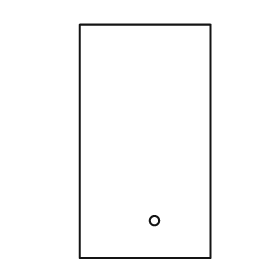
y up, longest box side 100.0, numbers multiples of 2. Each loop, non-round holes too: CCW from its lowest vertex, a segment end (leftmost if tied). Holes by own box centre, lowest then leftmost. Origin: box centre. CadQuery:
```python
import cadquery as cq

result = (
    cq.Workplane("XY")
    .moveTo(-28.0, -50.0)
    .lineTo(28.0, -50.0)
    .lineTo(28.0, 50.0)
    .lineTo(-28.0, 50.0)
    .close()
    .moveTo(4.0, -34.0)
    .circle(2.0)
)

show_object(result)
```